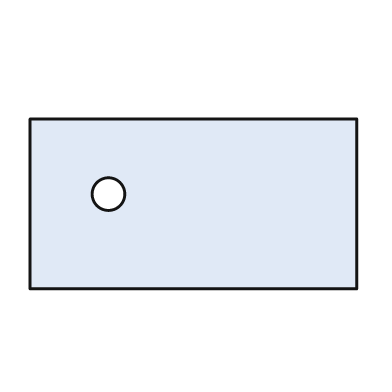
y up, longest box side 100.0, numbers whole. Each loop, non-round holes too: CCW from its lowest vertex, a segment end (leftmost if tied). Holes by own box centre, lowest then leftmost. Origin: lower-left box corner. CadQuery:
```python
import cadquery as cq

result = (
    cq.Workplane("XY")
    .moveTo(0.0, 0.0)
    .lineTo(100.0, 0.0)
    .lineTo(100.0, 52.0)
    .lineTo(0.0, 52.0)
    .close()
    .moveTo(24.0, 29.0)
    .circle(5.0)
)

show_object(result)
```